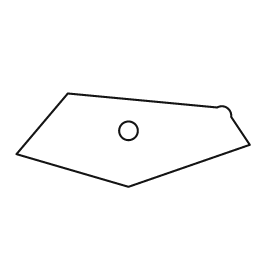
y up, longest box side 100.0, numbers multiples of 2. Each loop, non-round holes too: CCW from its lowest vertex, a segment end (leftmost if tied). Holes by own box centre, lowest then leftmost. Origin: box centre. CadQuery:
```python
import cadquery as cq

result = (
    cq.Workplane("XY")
    .moveTo(-2.0, -20.0)
    .lineTo(50.0, -2.0)
    .lineTo(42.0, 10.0)
    .threePointArc((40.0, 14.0), (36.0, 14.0))
    .lineTo(-28.0, 20.0)
    .lineTo(-50.0, -6.0)
    .close()
    .moveTo(-2.0, 4.0)
    .circle(4.0)
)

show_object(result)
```